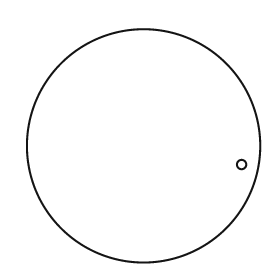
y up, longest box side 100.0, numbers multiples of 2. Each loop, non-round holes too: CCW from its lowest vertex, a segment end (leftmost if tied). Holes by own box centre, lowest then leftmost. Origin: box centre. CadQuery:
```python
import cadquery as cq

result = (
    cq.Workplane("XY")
    .moveTo(0.0, 0.0)
    .circle(50.0)
    .moveTo(42.0, -8.0)
    .circle(2.0)
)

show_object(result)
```